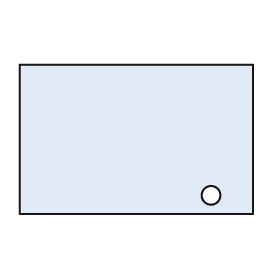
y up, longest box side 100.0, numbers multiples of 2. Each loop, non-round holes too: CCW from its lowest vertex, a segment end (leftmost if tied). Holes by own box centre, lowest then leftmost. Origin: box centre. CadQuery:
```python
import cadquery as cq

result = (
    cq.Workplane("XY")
    .moveTo(-50.0, -32.0)
    .lineTo(50.0, -32.0)
    .lineTo(50.0, 32.0)
    .lineTo(-50.0, 32.0)
    .close()
    .moveTo(32.0, -24.0)
    .circle(4.0)
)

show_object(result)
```